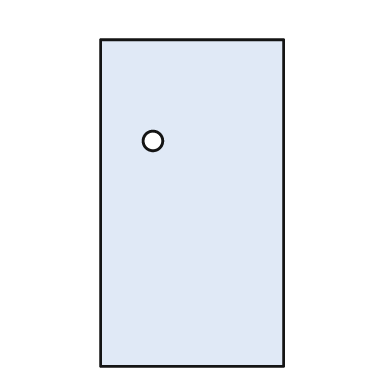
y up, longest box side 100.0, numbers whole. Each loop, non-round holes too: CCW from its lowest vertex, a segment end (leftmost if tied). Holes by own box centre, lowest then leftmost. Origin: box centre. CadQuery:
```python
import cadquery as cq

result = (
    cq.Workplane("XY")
    .moveTo(-28.0, -50.0)
    .lineTo(28.0, -50.0)
    .lineTo(28.0, 50.0)
    .lineTo(-28.0, 50.0)
    .close()
    .moveTo(-12.0, 19.0)
    .circle(3.0)
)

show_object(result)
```